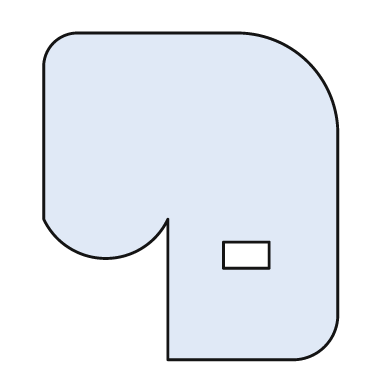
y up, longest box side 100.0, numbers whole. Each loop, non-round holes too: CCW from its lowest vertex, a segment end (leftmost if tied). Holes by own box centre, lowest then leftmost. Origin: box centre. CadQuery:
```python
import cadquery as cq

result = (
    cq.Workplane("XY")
    .moveTo(-7.0, -50.0)
    .lineTo(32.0, -50.0)
    .threePointArc((41.0, -46.0), (45.0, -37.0))
    .lineTo(45.0, 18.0)
    .threePointArc((36.0, 41.0), (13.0, 50.0))
    .lineTo(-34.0, 50.0)
    .threePointArc((-42.0, 47.0), (-45.0, 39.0))
    .lineTo(-45.0, -7.0)
    .threePointArc((-26.0, -19.0), (-7.0, -7.0))
    .close()
    .moveTo(10.0, -22.0)
    .lineTo(24.0, -22.0)
    .lineTo(24.0, -14.0)
    .lineTo(10.0, -14.0)
    .close()
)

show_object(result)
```